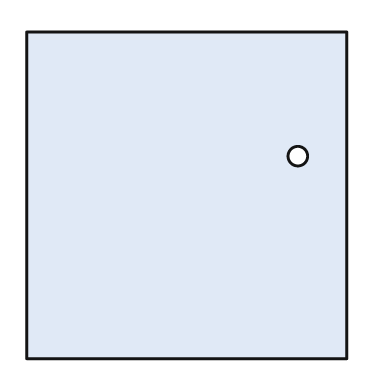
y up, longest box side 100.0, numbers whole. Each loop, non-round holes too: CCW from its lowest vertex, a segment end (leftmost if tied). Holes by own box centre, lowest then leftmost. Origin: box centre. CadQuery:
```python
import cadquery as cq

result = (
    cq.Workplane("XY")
    .moveTo(-49.0, -50.0)
    .lineTo(49.0, -50.0)
    .lineTo(49.0, 50.0)
    .lineTo(-49.0, 50.0)
    .close()
    .moveTo(34.0, 12.0)
    .circle(3.0)
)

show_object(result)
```